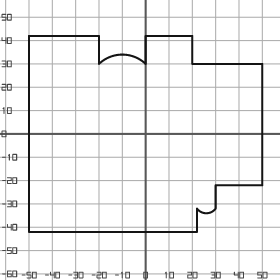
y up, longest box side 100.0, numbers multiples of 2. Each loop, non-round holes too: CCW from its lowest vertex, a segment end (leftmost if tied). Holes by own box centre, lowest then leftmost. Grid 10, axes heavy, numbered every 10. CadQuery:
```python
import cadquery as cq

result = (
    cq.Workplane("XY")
    .moveTo(-50.0, -42.0)
    .lineTo(22.0, -42.0)
    .lineTo(22.0, -32.0)
    .threePointArc((26.0, -34.0), (30.0, -32.0))
    .lineTo(30.0, -22.0)
    .lineTo(50.0, -22.0)
    .lineTo(50.0, 30.0)
    .lineTo(20.0, 30.0)
    .lineTo(20.0, 42.0)
    .lineTo(0.0, 42.0)
    .lineTo(0.0, 30.0)
    .threePointArc((-10.0, 34.0), (-20.0, 30.0))
    .lineTo(-20.0, 42.0)
    .lineTo(-50.0, 42.0)
    .close()
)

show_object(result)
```